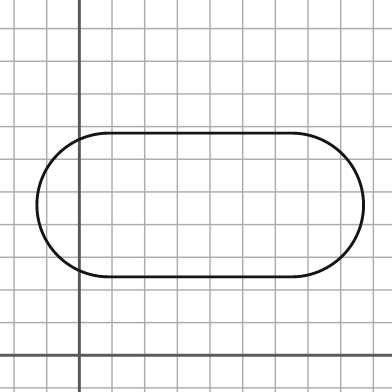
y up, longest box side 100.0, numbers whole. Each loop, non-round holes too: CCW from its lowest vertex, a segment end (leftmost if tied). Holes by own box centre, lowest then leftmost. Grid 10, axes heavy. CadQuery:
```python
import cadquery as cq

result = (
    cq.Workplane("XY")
    .moveTo(9.0, 24.0)
    .lineTo(65.0, 24.0)
    .threePointArc((87.0, 46.0), (65.0, 68.0))
    .lineTo(9.0, 68.0)
    .threePointArc((-13.0, 46.0), (9.0, 24.0))
    .close()
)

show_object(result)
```